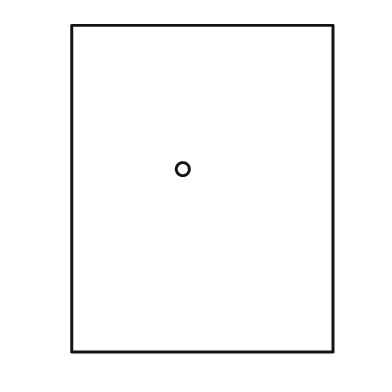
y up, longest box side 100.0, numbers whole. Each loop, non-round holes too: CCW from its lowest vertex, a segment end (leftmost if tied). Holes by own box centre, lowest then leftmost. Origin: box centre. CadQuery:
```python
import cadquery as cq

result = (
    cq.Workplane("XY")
    .moveTo(-40.0, -50.0)
    .lineTo(40.0, -50.0)
    .lineTo(40.0, 50.0)
    .lineTo(-40.0, 50.0)
    .close()
    .moveTo(-6.0, 6.0)
    .circle(2.0)
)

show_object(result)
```